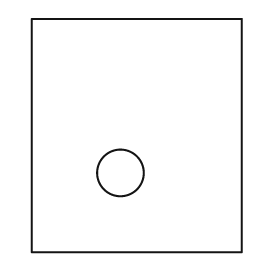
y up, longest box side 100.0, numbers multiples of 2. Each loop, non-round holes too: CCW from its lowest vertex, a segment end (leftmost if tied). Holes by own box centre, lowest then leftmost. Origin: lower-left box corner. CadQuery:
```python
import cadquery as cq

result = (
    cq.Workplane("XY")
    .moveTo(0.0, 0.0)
    .lineTo(90.0, 0.0)
    .lineTo(90.0, 100.0)
    .lineTo(0.0, 100.0)
    .close()
    .moveTo(38.0, 34.0)
    .circle(10.0)
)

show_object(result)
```